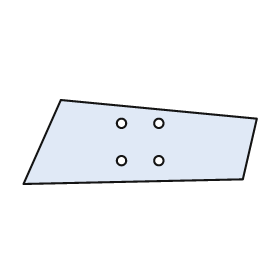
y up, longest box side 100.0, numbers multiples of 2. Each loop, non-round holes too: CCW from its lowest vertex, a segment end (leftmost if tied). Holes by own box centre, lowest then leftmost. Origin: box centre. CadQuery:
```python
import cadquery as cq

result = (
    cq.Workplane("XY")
    .moveTo(-50.0, -18.0)
    .lineTo(44.0, -16.0)
    .lineTo(50.0, 10.0)
    .lineTo(-34.0, 18.0)
    .close()
    .moveTo(-8.0, -8.0)
    .circle(2.0)
    .moveTo(8.0, -8.0)
    .circle(2.0)
    .moveTo(-8.0, 8.0)
    .circle(2.0)
    .moveTo(8.0, 8.0)
    .circle(2.0)
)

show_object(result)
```